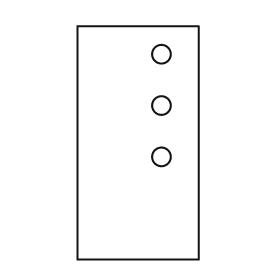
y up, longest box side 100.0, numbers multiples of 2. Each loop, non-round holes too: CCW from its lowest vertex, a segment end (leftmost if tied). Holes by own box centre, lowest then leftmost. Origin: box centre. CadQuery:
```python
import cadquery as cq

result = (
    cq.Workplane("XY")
    .moveTo(-26.0, -50.0)
    .lineTo(26.0, -50.0)
    .lineTo(26.0, 50.0)
    .lineTo(-26.0, 50.0)
    .close()
    .moveTo(10.0, -6.0)
    .circle(4.0)
    .moveTo(10.0, 16.0)
    .circle(4.0)
    .moveTo(10.0, 38.0)
    .circle(4.0)
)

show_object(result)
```